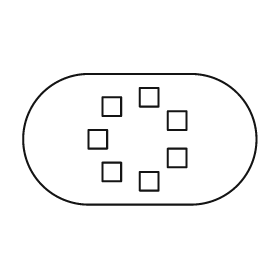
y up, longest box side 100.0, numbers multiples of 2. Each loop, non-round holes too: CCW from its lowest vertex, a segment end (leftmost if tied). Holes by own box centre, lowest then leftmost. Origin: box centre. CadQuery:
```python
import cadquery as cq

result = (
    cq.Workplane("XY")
    .moveTo(-22.0, -28.0)
    .lineTo(22.0, -28.0)
    .threePointArc((50.0, 0.0), (22.0, 28.0))
    .lineTo(-22.0, 28.0)
    .threePointArc((-50.0, 0.0), (-22.0, -28.0))
    .close()
    .moveTo(0.0, -22.0)
    .lineTo(8.0, -22.0)
    .lineTo(8.0, -14.0)
    .lineTo(0.0, -14.0)
    .close()
    .moveTo(-16.0, -18.0)
    .lineTo(-8.0, -18.0)
    .lineTo(-8.0, -10.0)
    .lineTo(-16.0, -10.0)
    .close()
    .moveTo(12.0, -12.0)
    .lineTo(20.0, -12.0)
    .lineTo(20.0, -4.0)
    .lineTo(12.0, -4.0)
    .close()
    .moveTo(-22.0, -4.0)
    .lineTo(-14.0, -4.0)
    .lineTo(-14.0, 4.0)
    .lineTo(-22.0, 4.0)
    .close()
    .moveTo(12.0, 4.0)
    .lineTo(20.0, 4.0)
    .lineTo(20.0, 12.0)
    .lineTo(12.0, 12.0)
    .close()
    .moveTo(-16.0, 10.0)
    .lineTo(-8.0, 10.0)
    .lineTo(-8.0, 18.0)
    .lineTo(-16.0, 18.0)
    .close()
    .moveTo(0.0, 14.0)
    .lineTo(8.0, 14.0)
    .lineTo(8.0, 22.0)
    .lineTo(0.0, 22.0)
    .close()
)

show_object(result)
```